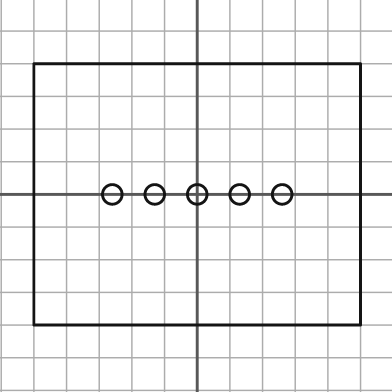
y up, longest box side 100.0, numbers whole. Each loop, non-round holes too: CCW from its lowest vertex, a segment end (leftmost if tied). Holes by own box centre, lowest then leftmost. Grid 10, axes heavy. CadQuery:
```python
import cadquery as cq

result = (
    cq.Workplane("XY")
    .moveTo(-50.0, -40.0)
    .lineTo(50.0, -40.0)
    .lineTo(50.0, 40.0)
    .lineTo(-50.0, 40.0)
    .close()
    .moveTo(-26.0, 0.0)
    .circle(3.0)
    .moveTo(-13.0, 0.0)
    .circle(3.0)
    .moveTo(0.0, 0.0)
    .circle(3.0)
    .moveTo(13.0, 0.0)
    .circle(3.0)
    .moveTo(26.0, 0.0)
    .circle(3.0)
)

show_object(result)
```